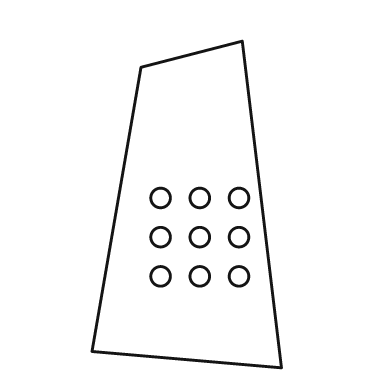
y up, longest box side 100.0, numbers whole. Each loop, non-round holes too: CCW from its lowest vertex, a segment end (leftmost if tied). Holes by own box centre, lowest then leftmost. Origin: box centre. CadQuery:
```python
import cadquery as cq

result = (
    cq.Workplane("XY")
    .moveTo(29.0, -50.0)
    .lineTo(17.0, 50.0)
    .lineTo(-14.0, 42.0)
    .lineTo(-29.0, -45.0)
    .close()
    .moveTo(-8.0, -22.0)
    .circle(3.0)
    .moveTo(4.0, -22.0)
    .circle(3.0)
    .moveTo(16.0, -22.0)
    .circle(3.0)
    .moveTo(-8.0, -10.0)
    .circle(3.0)
    .moveTo(4.0, -10.0)
    .circle(3.0)
    .moveTo(16.0, -10.0)
    .circle(3.0)
    .moveTo(-8.0, 2.0)
    .circle(3.0)
    .moveTo(4.0, 2.0)
    .circle(3.0)
    .moveTo(16.0, 2.0)
    .circle(3.0)
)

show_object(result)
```